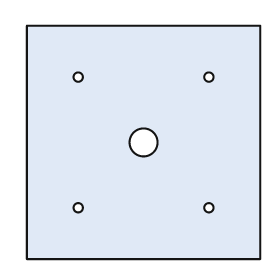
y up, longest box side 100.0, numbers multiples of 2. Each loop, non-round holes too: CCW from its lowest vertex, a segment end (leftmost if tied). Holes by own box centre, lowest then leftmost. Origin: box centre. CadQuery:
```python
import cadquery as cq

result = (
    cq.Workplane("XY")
    .moveTo(-50.0, -50.0)
    .lineTo(50.0, -50.0)
    .lineTo(50.0, 50.0)
    .lineTo(-50.0, 50.0)
    .close()
    .moveTo(-28.0, -28.0)
    .circle(2.0)
    .moveTo(28.0, -28.0)
    .circle(2.0)
    .moveTo(0.0, 0.0)
    .circle(6.0)
    .moveTo(-28.0, 28.0)
    .circle(2.0)
    .moveTo(28.0, 28.0)
    .circle(2.0)
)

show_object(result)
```